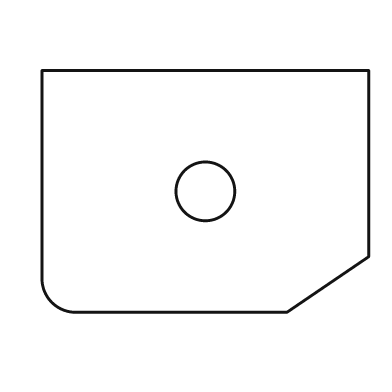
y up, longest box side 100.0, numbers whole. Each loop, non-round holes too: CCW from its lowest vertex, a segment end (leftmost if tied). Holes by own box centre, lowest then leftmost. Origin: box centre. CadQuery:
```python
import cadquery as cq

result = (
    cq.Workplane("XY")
    .moveTo(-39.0, -37.0)
    .lineTo(25.0, -37.0)
    .lineTo(50.0, -20.0)
    .lineTo(50.0, 37.0)
    .lineTo(-50.0, 37.0)
    .lineTo(-50.0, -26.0)
    .threePointArc((-47.0, -34.0), (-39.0, -37.0))
    .close()
    .moveTo(0.0, 0.0)
    .circle(9.0)
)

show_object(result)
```